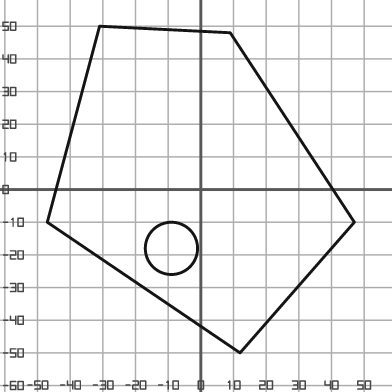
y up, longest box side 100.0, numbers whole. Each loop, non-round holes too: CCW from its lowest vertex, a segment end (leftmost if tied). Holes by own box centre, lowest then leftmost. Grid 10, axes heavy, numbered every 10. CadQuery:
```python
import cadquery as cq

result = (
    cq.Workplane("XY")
    .moveTo(12.0, -50.0)
    .lineTo(47.0, -10.0)
    .lineTo(9.0, 48.0)
    .lineTo(-31.0, 50.0)
    .lineTo(-47.0, -10.0)
    .close()
    .moveTo(-9.0, -18.0)
    .circle(8.0)
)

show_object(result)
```